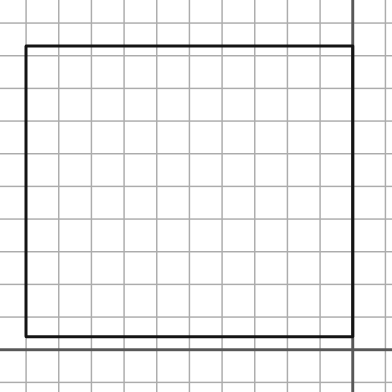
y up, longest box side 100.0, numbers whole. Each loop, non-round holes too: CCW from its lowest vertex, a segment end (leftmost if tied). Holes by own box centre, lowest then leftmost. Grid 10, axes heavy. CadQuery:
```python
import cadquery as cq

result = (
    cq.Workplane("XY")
    .moveTo(-100.0, 4.0)
    .lineTo(0.0, 4.0)
    .lineTo(0.0, 93.0)
    .lineTo(-100.0, 93.0)
    .close()
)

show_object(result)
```